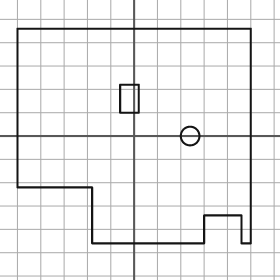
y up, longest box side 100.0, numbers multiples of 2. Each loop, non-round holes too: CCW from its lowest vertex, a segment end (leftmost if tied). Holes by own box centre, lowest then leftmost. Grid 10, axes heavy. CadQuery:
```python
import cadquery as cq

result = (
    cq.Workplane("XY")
    .moveTo(-18.0, -46.0)
    .lineTo(30.0, -46.0)
    .lineTo(30.0, -34.0)
    .lineTo(46.0, -34.0)
    .lineTo(46.0, -46.0)
    .lineTo(50.0, -46.0)
    .lineTo(50.0, 46.0)
    .lineTo(-50.0, 46.0)
    .lineTo(-50.0, -22.0)
    .lineTo(-18.0, -22.0)
    .close()
    .moveTo(24.0, 0.0)
    .circle(4.0)
    .moveTo(-6.0, 10.0)
    .lineTo(2.0, 10.0)
    .lineTo(2.0, 22.0)
    .lineTo(-6.0, 22.0)
    .close()
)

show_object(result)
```